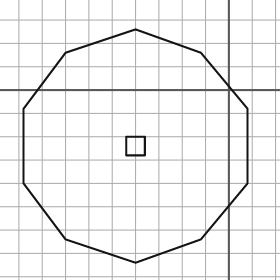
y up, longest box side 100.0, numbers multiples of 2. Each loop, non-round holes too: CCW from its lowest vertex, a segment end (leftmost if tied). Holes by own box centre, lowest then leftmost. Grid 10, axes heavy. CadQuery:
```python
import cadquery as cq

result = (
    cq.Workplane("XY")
    .moveTo(-40.0, -74.0)
    .lineTo(-12.0, -64.0)
    .lineTo(8.0, -40.0)
    .lineTo(8.0, -8.0)
    .lineTo(-12.0, 16.0)
    .lineTo(-40.0, 26.0)
    .lineTo(-70.0, 16.0)
    .lineTo(-88.0, -8.0)
    .lineTo(-88.0, -40.0)
    .lineTo(-70.0, -64.0)
    .close()
    .moveTo(-44.0, -28.0)
    .lineTo(-36.0, -28.0)
    .lineTo(-36.0, -20.0)
    .lineTo(-44.0, -20.0)
    .close()
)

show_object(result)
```